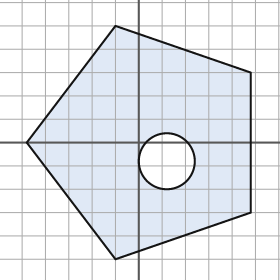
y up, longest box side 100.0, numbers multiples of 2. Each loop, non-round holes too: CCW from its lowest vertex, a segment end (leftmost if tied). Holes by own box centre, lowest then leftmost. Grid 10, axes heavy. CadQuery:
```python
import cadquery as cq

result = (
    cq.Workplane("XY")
    .moveTo(-10.0, -50.0)
    .lineTo(48.0, -30.0)
    .lineTo(48.0, 30.0)
    .lineTo(-10.0, 50.0)
    .lineTo(-48.0, 0.0)
    .close()
    .moveTo(12.0, -8.0)
    .circle(12.0)
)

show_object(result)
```